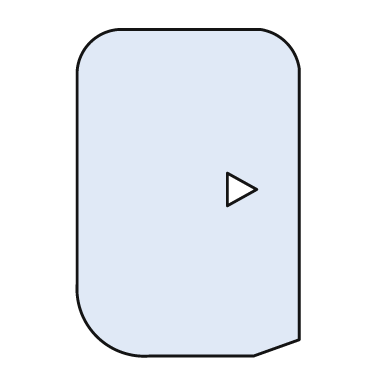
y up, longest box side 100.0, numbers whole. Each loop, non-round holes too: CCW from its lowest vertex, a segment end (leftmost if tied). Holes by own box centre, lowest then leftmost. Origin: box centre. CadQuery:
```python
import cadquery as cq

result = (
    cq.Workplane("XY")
    .moveTo(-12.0, -50.0)
    .lineTo(20.0, -50.0)
    .lineTo(34.0, -45.0)
    .lineTo(34.0, 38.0)
    .threePointArc((30.0, 46.0), (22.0, 50.0))
    .lineTo(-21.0, 50.0)
    .threePointArc((-30.0, 46.0), (-34.0, 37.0))
    .lineTo(-34.0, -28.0)
    .threePointArc((-28.0, -44.0), (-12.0, -50.0))
    .close()
    .moveTo(12.0, -4.0)
    .lineTo(21.0, 1.0)
    .lineTo(12.0, 6.0)
    .close()
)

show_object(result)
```